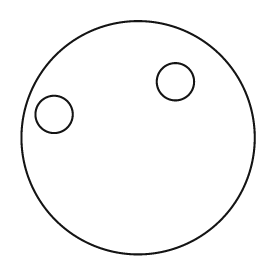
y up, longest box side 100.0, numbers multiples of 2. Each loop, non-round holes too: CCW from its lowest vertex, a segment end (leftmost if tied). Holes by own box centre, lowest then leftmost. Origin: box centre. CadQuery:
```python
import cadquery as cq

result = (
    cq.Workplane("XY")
    .moveTo(0.0, 0.0)
    .circle(50.0)
    .moveTo(-36.0, 10.0)
    .circle(8.0)
    .moveTo(16.0, 24.0)
    .circle(8.0)
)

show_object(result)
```